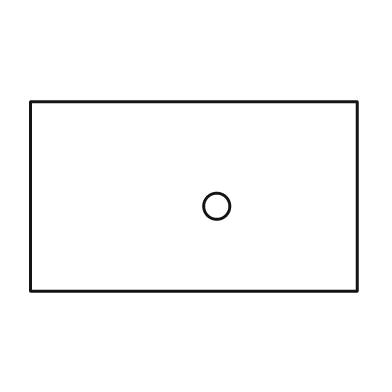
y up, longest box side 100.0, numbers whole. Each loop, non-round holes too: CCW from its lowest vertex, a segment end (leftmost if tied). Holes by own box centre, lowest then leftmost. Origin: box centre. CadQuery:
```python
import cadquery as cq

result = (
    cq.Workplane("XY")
    .moveTo(-50.0, -29.0)
    .lineTo(50.0, -29.0)
    .lineTo(50.0, 29.0)
    .lineTo(-50.0, 29.0)
    .close()
    .moveTo(7.0, -3.0)
    .circle(4.0)
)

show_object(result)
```